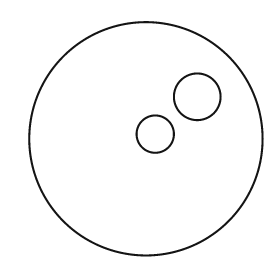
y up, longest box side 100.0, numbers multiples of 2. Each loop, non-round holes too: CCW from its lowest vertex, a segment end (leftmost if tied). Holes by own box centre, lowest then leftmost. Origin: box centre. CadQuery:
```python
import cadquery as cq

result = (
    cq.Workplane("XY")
    .moveTo(0.0, 0.0)
    .circle(50.0)
    .moveTo(4.0, 2.0)
    .circle(8.0)
    .moveTo(22.0, 18.0)
    .circle(10.0)
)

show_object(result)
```